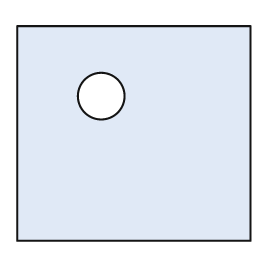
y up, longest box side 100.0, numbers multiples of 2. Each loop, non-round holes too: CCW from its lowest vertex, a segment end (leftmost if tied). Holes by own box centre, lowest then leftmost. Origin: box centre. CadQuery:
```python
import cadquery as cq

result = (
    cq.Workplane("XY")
    .moveTo(-50.0, -46.0)
    .lineTo(50.0, -46.0)
    .lineTo(50.0, 46.0)
    .lineTo(-50.0, 46.0)
    .close()
    .moveTo(-14.0, 16.0)
    .circle(10.0)
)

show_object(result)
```